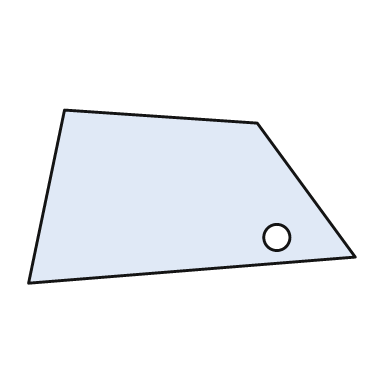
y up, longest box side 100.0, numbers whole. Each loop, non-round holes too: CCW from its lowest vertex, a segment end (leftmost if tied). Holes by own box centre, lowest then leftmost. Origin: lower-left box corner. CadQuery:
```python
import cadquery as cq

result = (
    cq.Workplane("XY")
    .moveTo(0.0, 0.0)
    .lineTo(100.0, 8.0)
    .lineTo(70.0, 49.0)
    .lineTo(11.0, 53.0)
    .close()
    .moveTo(76.0, 14.0)
    .circle(4.0)
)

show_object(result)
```